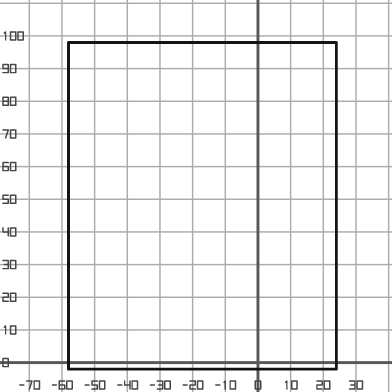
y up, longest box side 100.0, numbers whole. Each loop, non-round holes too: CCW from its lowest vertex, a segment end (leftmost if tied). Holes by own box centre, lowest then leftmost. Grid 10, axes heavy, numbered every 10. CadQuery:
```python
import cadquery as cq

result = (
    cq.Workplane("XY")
    .moveTo(-58.0, -2.0)
    .lineTo(24.0, -2.0)
    .lineTo(24.0, 98.0)
    .lineTo(-58.0, 98.0)
    .close()
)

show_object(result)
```